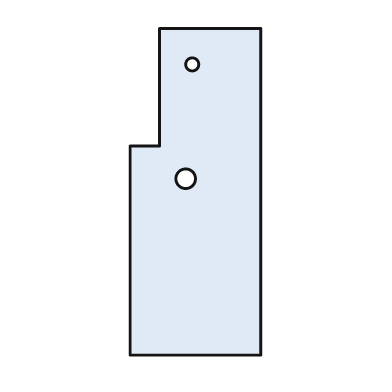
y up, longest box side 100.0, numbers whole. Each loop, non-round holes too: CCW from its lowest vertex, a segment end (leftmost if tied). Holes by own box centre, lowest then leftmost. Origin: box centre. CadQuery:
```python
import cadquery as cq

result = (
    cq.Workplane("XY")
    .moveTo(-20.0, -50.0)
    .lineTo(20.0, -50.0)
    .lineTo(20.0, 50.0)
    .lineTo(-11.0, 50.0)
    .lineTo(-11.0, 14.0)
    .lineTo(-20.0, 14.0)
    .close()
    .moveTo(-3.0, 4.0)
    .circle(3.0)
    .moveTo(-1.0, 39.0)
    .circle(2.0)
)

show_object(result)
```